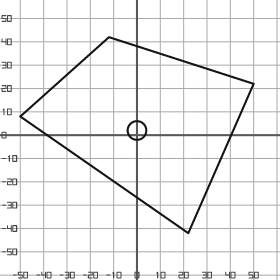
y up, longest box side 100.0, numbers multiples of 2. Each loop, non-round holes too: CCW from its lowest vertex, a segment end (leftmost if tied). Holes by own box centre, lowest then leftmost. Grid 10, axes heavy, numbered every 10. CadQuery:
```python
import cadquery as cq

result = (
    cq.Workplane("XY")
    .moveTo(22.0, -42.0)
    .lineTo(50.0, 22.0)
    .lineTo(-12.0, 42.0)
    .lineTo(-50.0, 8.0)
    .close()
    .moveTo(0.0, 2.0)
    .circle(4.0)
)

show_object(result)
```